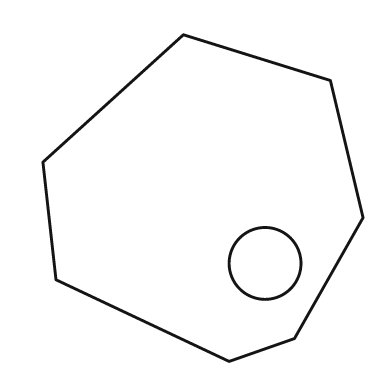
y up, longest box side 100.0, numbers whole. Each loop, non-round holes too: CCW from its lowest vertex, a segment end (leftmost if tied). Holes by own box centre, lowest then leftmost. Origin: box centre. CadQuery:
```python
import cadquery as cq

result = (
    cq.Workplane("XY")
    .moveTo(8.0, -50.0)
    .lineTo(28.0, -43.0)
    .lineTo(49.0, -6.0)
    .lineTo(39.0, 36.0)
    .lineTo(-6.0, 50.0)
    .lineTo(-49.0, 11.0)
    .lineTo(-45.0, -25.0)
    .close()
    .moveTo(19.0, -20.0)
    .circle(11.0)
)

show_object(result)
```